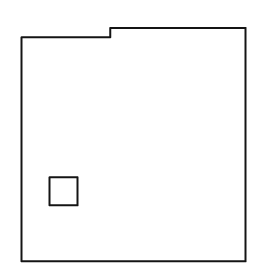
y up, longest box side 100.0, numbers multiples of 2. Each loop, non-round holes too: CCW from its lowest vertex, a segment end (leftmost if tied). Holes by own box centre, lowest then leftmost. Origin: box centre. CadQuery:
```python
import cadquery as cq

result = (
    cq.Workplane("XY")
    .moveTo(-48.0, -50.0)
    .lineTo(48.0, -50.0)
    .lineTo(48.0, 50.0)
    .lineTo(-10.0, 50.0)
    .lineTo(-10.0, 46.0)
    .lineTo(-48.0, 46.0)
    .close()
    .moveTo(-36.0, -26.0)
    .lineTo(-24.0, -26.0)
    .lineTo(-24.0, -14.0)
    .lineTo(-36.0, -14.0)
    .close()
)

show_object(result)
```